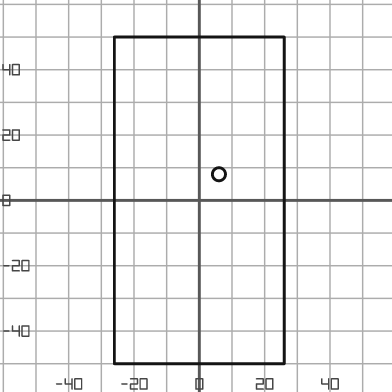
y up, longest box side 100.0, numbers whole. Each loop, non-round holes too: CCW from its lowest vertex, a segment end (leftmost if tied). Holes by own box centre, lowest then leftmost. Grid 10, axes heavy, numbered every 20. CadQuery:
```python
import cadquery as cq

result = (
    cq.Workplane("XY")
    .moveTo(-26.0, -50.0)
    .lineTo(26.0, -50.0)
    .lineTo(26.0, 50.0)
    .lineTo(-26.0, 50.0)
    .close()
    .moveTo(6.0, 8.0)
    .circle(2.0)
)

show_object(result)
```